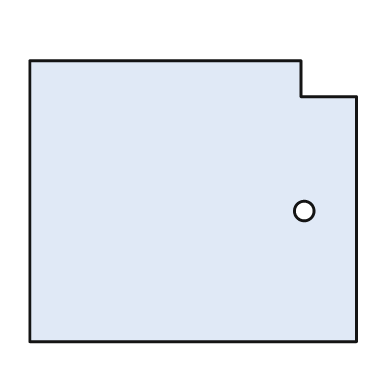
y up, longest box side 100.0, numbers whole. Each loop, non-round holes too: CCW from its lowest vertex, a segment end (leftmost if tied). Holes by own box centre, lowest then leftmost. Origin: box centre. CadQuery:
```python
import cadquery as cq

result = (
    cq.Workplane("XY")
    .moveTo(-50.0, -43.0)
    .lineTo(50.0, -43.0)
    .lineTo(50.0, 32.0)
    .lineTo(33.0, 32.0)
    .lineTo(33.0, 43.0)
    .lineTo(-50.0, 43.0)
    .close()
    .moveTo(34.0, -3.0)
    .circle(3.0)
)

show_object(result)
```